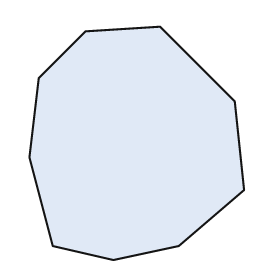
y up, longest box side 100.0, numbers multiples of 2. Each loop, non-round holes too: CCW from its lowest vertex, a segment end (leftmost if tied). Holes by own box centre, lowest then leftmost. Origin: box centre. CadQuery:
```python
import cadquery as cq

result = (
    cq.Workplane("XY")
    .moveTo(-10.0, -50.0)
    .lineTo(18.0, -44.0)
    .lineTo(46.0, -20.0)
    .lineTo(42.0, 18.0)
    .lineTo(10.0, 50.0)
    .lineTo(-22.0, 48.0)
    .lineTo(-42.0, 28.0)
    .lineTo(-46.0, -6.0)
    .lineTo(-36.0, -44.0)
    .close()
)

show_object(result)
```